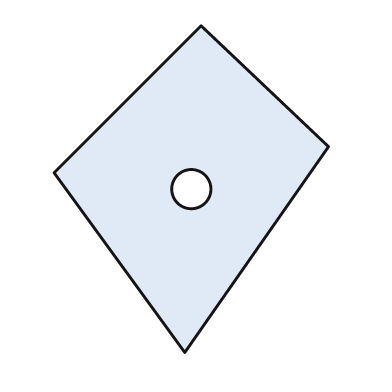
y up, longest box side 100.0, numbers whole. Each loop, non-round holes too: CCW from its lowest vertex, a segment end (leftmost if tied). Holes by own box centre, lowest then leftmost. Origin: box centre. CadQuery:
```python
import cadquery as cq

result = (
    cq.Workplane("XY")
    .moveTo(-2.0, -50.0)
    .lineTo(42.0, 13.0)
    .lineTo(3.0, 50.0)
    .lineTo(-42.0, 5.0)
    .close()
    .moveTo(0.0, 0.0)
    .circle(6.0)
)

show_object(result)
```